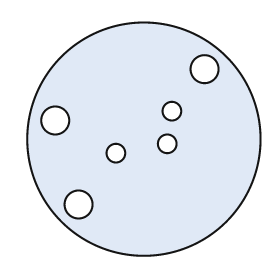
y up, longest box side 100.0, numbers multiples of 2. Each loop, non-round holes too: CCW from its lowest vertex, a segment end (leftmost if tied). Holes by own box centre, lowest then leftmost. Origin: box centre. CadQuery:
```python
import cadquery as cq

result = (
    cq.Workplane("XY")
    .moveTo(0.0, 0.0)
    .circle(50.0)
    .moveTo(-28.0, -28.0)
    .circle(6.0)
    .moveTo(-12.0, -6.0)
    .circle(4.0)
    .moveTo(10.0, -2.0)
    .circle(4.0)
    .moveTo(-38.0, 8.0)
    .circle(6.0)
    .moveTo(12.0, 12.0)
    .circle(4.0)
    .moveTo(26.0, 30.0)
    .circle(6.0)
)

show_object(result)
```